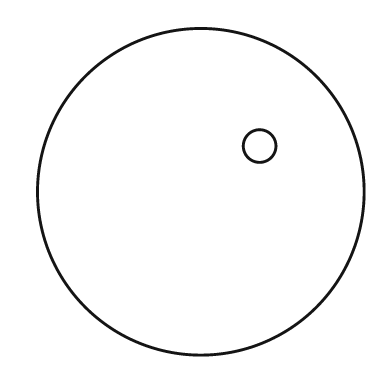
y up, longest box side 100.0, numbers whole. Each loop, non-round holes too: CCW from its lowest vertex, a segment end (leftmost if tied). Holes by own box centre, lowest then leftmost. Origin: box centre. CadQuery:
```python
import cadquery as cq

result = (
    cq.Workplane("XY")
    .moveTo(0.0, 0.0)
    .circle(50.0)
    .moveTo(18.0, 14.0)
    .circle(5.0)
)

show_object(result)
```